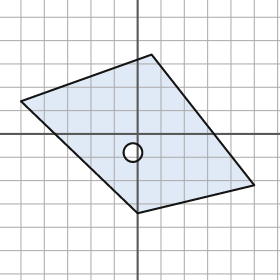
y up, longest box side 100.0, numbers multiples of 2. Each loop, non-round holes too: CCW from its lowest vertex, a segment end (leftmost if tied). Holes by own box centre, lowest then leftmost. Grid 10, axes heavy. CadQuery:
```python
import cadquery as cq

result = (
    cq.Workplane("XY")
    .moveTo(0.0, -34.0)
    .lineTo(50.0, -22.0)
    .lineTo(6.0, 34.0)
    .lineTo(-50.0, 14.0)
    .close()
    .moveTo(-2.0, -8.0)
    .circle(4.0)
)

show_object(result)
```